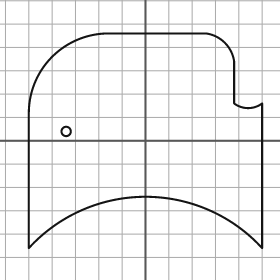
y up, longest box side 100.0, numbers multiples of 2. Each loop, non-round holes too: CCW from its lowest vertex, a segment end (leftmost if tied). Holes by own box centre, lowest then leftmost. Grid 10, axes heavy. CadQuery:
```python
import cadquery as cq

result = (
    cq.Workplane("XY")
    .moveTo(-50.0, -46.0)
    .threePointArc((0.0, -24.0), (50.0, -46.0))
    .lineTo(50.0, 16.0)
    .threePointArc((44.0, 14.0), (38.0, 16.0))
    .lineTo(38.0, 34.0)
    .threePointArc((34.0, 42.0), (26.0, 46.0))
    .lineTo(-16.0, 46.0)
    .threePointArc((-40.0, 36.0), (-50.0, 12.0))
    .close()
    .moveTo(-34.0, 4.0)
    .circle(2.0)
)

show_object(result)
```